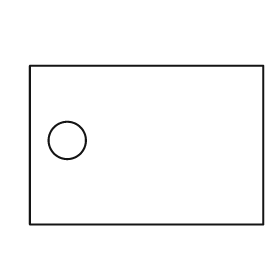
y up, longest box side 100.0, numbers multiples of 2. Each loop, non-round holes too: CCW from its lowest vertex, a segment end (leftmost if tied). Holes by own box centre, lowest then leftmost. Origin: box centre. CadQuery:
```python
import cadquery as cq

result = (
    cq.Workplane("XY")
    .moveTo(-50.0, -34.0)
    .lineTo(50.0, -34.0)
    .lineTo(50.0, 34.0)
    .lineTo(-50.0, 34.0)
    .close()
    .moveTo(-34.0, 2.0)
    .circle(8.0)
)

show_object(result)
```